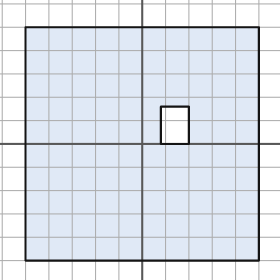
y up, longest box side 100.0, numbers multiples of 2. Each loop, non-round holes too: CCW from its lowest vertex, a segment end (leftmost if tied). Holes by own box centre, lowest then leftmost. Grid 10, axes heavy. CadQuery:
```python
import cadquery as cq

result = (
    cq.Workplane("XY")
    .moveTo(-50.0, -50.0)
    .lineTo(50.0, -50.0)
    .lineTo(50.0, 50.0)
    .lineTo(-50.0, 50.0)
    .close()
    .moveTo(8.0, 0.0)
    .lineTo(20.0, 0.0)
    .lineTo(20.0, 16.0)
    .lineTo(8.0, 16.0)
    .close()
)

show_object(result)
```